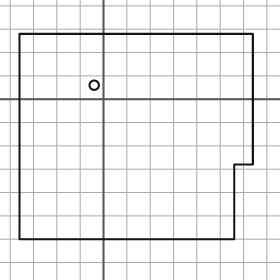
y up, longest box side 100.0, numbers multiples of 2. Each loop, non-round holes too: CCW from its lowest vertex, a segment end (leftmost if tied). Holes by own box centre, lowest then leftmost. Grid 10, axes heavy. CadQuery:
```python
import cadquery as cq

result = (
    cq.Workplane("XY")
    .moveTo(-36.0, -60.0)
    .lineTo(56.0, -60.0)
    .lineTo(56.0, -28.0)
    .lineTo(64.0, -28.0)
    .lineTo(64.0, 28.0)
    .lineTo(-36.0, 28.0)
    .close()
    .moveTo(-4.0, 6.0)
    .circle(2.0)
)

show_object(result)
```